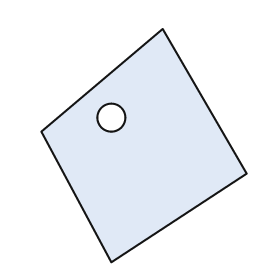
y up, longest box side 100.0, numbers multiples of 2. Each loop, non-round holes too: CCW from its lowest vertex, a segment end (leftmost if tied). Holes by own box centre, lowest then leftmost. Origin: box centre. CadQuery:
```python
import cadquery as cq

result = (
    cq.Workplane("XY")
    .moveTo(-14.0, -50.0)
    .lineTo(44.0, -12.0)
    .lineTo(8.0, 50.0)
    .lineTo(-44.0, 6.0)
    .close()
    .moveTo(-14.0, 12.0)
    .circle(6.0)
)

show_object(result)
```